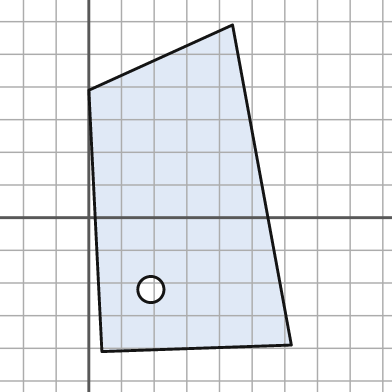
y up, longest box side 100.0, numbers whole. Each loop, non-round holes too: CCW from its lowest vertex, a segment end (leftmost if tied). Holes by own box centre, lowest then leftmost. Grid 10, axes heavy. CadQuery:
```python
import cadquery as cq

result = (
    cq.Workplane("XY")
    .moveTo(4.0, -41.0)
    .lineTo(62.0, -39.0)
    .lineTo(44.0, 59.0)
    .lineTo(0.0, 39.0)
    .close()
    .moveTo(19.0, -22.0)
    .circle(4.0)
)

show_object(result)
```